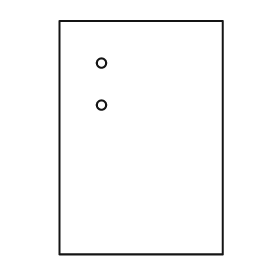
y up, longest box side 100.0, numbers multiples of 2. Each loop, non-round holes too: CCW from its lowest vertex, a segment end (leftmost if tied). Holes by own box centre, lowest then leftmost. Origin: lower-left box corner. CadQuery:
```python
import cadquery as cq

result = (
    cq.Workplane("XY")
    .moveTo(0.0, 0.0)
    .lineTo(70.0, 0.0)
    .lineTo(70.0, 100.0)
    .lineTo(0.0, 100.0)
    .close()
    .moveTo(18.0, 64.0)
    .circle(2.0)
    .moveTo(18.0, 82.0)
    .circle(2.0)
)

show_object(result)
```